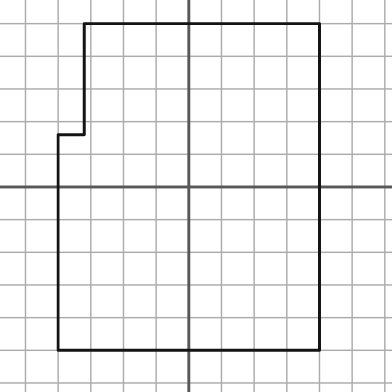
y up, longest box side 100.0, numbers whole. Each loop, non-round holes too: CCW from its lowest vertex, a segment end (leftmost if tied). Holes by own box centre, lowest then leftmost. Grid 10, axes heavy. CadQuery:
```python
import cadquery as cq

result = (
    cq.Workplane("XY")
    .moveTo(-40.0, -50.0)
    .lineTo(40.0, -50.0)
    .lineTo(40.0, 50.0)
    .lineTo(-32.0, 50.0)
    .lineTo(-32.0, 16.0)
    .lineTo(-40.0, 16.0)
    .close()
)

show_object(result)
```